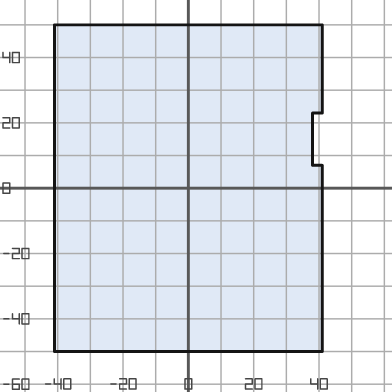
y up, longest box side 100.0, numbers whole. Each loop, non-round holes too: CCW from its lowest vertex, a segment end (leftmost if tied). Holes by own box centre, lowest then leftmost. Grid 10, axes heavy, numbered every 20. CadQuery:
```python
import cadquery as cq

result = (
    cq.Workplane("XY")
    .moveTo(-41.0, -50.0)
    .lineTo(41.0, -50.0)
    .lineTo(41.0, 7.0)
    .lineTo(38.0, 7.0)
    .lineTo(38.0, 23.0)
    .lineTo(41.0, 23.0)
    .lineTo(41.0, 50.0)
    .lineTo(-41.0, 50.0)
    .close()
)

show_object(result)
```